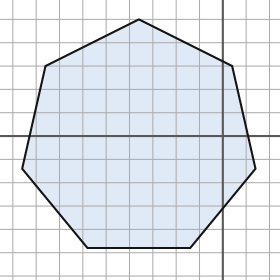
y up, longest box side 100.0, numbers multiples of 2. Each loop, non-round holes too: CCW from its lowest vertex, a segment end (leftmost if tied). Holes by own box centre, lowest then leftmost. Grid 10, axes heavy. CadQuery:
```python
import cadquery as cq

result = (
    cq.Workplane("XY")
    .moveTo(-58.0, -48.0)
    .lineTo(-14.0, -48.0)
    .lineTo(14.0, -14.0)
    .lineTo(4.0, 30.0)
    .lineTo(-36.0, 50.0)
    .lineTo(-76.0, 30.0)
    .lineTo(-86.0, -14.0)
    .close()
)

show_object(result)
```